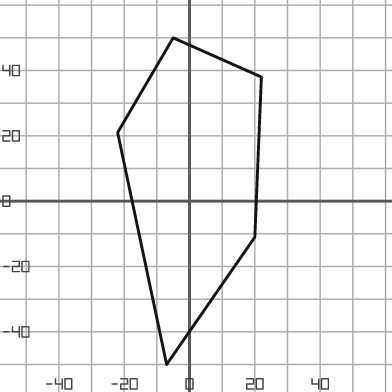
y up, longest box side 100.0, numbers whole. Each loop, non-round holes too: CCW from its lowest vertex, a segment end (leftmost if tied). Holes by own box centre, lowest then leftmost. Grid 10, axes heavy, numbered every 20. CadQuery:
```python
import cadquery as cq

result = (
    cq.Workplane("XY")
    .moveTo(-7.0, -50.0)
    .lineTo(20.0, -11.0)
    .lineTo(22.0, 38.0)
    .lineTo(-5.0, 50.0)
    .lineTo(-22.0, 21.0)
    .close()
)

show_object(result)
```